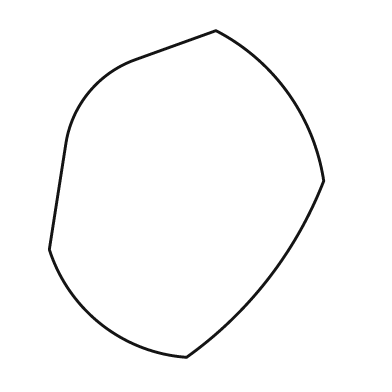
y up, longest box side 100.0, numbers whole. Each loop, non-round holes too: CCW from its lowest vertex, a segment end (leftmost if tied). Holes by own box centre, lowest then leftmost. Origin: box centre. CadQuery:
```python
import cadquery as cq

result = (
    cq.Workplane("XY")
    .moveTo(0.0, -50.0)
    .threePointArc((25.0, -26.0), (42.0, 4.0))
    .threePointArc((31.0, 31.0), (9.0, 50.0))
    .lineTo(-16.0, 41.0)
    .threePointArc((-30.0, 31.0), (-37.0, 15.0))
    .lineTo(-42.0, -17.0)
    .threePointArc((-26.0, -40.0), (0.0, -50.0))
    .close()
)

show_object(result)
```